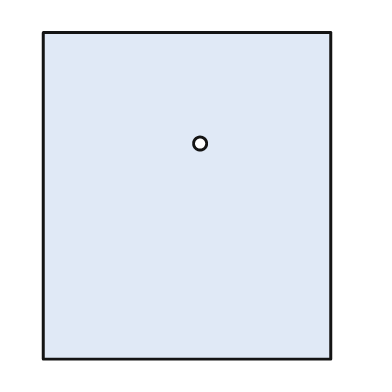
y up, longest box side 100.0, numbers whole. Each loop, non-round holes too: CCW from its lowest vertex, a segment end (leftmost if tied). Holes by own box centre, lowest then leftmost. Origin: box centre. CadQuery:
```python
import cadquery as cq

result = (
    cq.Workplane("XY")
    .moveTo(-44.0, -50.0)
    .lineTo(44.0, -50.0)
    .lineTo(44.0, 50.0)
    .lineTo(-44.0, 50.0)
    .close()
    .moveTo(4.0, 16.0)
    .circle(2.0)
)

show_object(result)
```